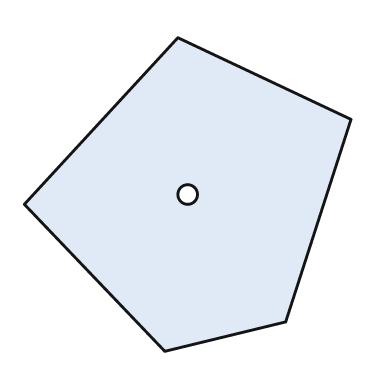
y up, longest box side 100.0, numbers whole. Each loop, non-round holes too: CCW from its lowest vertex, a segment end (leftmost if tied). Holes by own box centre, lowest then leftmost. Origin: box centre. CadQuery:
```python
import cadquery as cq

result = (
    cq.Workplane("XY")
    .moveTo(-7.0, -48.0)
    .lineTo(30.0, -39.0)
    .lineTo(50.0, 23.0)
    .lineTo(-3.0, 48.0)
    .lineTo(-50.0, -3.0)
    .close()
    .moveTo(0.0, 0.0)
    .circle(3.0)
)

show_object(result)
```